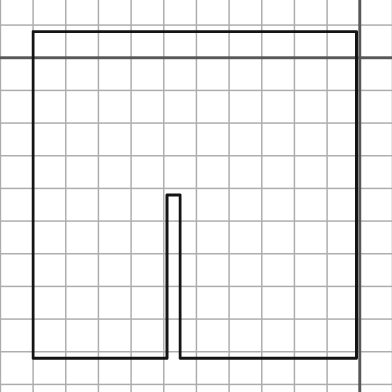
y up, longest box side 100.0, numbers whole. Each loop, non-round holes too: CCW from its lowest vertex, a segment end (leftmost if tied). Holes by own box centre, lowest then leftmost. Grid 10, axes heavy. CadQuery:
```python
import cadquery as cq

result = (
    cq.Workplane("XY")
    .moveTo(-100.0, -92.0)
    .lineTo(-59.0, -92.0)
    .lineTo(-59.0, -42.0)
    .lineTo(-55.0, -42.0)
    .lineTo(-55.0, -92.0)
    .lineTo(-1.0, -92.0)
    .lineTo(-1.0, 8.0)
    .lineTo(-100.0, 8.0)
    .close()
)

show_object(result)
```